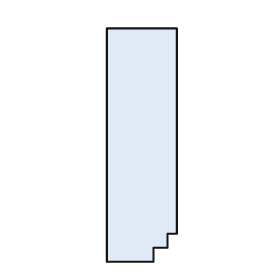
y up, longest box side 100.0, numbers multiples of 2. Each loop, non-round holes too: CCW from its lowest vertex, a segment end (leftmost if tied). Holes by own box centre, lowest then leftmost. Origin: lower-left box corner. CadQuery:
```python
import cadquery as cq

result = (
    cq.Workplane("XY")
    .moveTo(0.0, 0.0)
    .lineTo(20.0, 0.0)
    .lineTo(20.0, 6.0)
    .lineTo(26.0, 6.0)
    .lineTo(26.0, 12.0)
    .lineTo(30.0, 12.0)
    .lineTo(30.0, 100.0)
    .lineTo(0.0, 100.0)
    .close()
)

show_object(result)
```